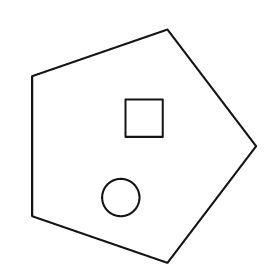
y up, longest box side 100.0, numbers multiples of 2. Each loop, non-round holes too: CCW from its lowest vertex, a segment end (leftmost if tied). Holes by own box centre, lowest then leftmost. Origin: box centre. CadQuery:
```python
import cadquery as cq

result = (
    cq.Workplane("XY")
    .moveTo(10.0, -50.0)
    .lineTo(48.0, 0.0)
    .lineTo(10.0, 50.0)
    .lineTo(-48.0, 30.0)
    .lineTo(-48.0, -30.0)
    .close()
    .moveTo(-10.0, -22.0)
    .circle(8.0)
    .moveTo(-8.0, 4.0)
    .lineTo(8.0, 4.0)
    .lineTo(8.0, 20.0)
    .lineTo(-8.0, 20.0)
    .close()
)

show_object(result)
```